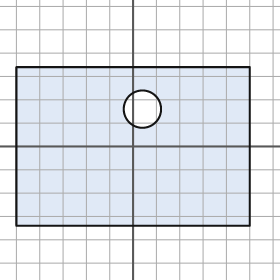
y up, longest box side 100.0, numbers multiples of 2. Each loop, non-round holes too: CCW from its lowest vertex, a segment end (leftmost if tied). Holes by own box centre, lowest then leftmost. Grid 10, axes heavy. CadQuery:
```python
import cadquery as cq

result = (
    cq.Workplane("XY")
    .moveTo(-50.0, -34.0)
    .lineTo(50.0, -34.0)
    .lineTo(50.0, 34.0)
    .lineTo(-50.0, 34.0)
    .close()
    .moveTo(4.0, 16.0)
    .circle(8.0)
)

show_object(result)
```